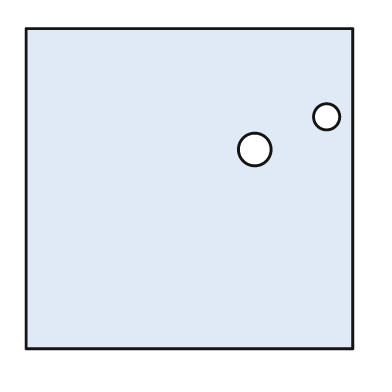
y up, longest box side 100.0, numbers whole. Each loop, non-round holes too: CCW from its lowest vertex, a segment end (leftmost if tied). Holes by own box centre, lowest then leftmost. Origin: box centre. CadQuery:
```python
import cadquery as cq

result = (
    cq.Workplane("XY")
    .moveTo(-50.0, -49.0)
    .lineTo(50.0, -49.0)
    .lineTo(50.0, 49.0)
    .lineTo(-50.0, 49.0)
    .close()
    .moveTo(20.0, 12.0)
    .circle(5.0)
    .moveTo(42.0, 22.0)
    .circle(4.0)
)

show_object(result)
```